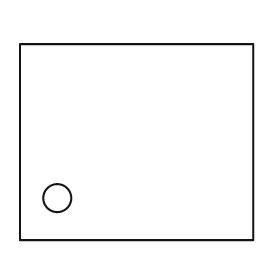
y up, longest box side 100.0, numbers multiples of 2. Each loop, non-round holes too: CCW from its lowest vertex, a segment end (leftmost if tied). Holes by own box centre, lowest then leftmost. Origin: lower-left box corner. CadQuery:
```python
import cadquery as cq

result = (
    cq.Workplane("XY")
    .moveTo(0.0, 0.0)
    .lineTo(100.0, 0.0)
    .lineTo(100.0, 84.0)
    .lineTo(0.0, 84.0)
    .close()
    .moveTo(16.0, 18.0)
    .circle(6.0)
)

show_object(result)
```